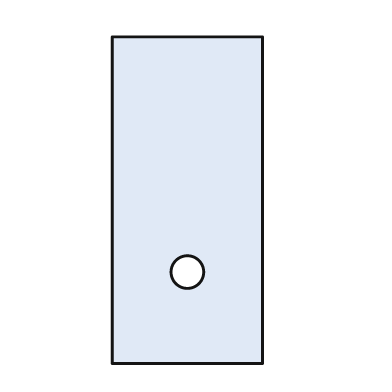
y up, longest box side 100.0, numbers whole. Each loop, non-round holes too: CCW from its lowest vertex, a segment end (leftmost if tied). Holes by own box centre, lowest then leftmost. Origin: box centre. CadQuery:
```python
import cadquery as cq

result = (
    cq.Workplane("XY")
    .moveTo(-23.0, -50.0)
    .lineTo(23.0, -50.0)
    .lineTo(23.0, 50.0)
    .lineTo(-23.0, 50.0)
    .close()
    .moveTo(0.0, -22.0)
    .circle(5.0)
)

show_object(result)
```